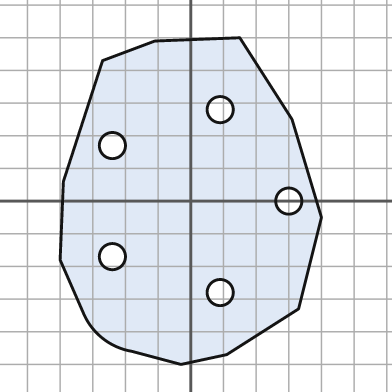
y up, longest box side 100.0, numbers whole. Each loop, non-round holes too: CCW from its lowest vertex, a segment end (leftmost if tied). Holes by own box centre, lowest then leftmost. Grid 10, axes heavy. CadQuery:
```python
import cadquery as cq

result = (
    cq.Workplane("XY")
    .moveTo(-3.0, -50.0)
    .lineTo(11.0, -47.0)
    .lineTo(33.0, -33.0)
    .lineTo(40.0, -5.0)
    .lineTo(31.0, 25.0)
    .lineTo(15.0, 50.0)
    .lineTo(-11.0, 49.0)
    .lineTo(-27.0, 43.0)
    .lineTo(-39.0, 6.0)
    .lineTo(-40.0, -18.0)
    .lineTo(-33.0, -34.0)
    .threePointArc((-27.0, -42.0), (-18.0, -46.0))
    .close()
    .moveTo(9.0, -28.0)
    .circle(4.0)
    .moveTo(-24.0, -17.0)
    .circle(4.0)
    .moveTo(30.0, 0.0)
    .circle(4.0)
    .moveTo(-24.0, 17.0)
    .circle(4.0)
    .moveTo(9.0, 28.0)
    .circle(4.0)
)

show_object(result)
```